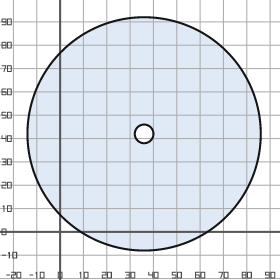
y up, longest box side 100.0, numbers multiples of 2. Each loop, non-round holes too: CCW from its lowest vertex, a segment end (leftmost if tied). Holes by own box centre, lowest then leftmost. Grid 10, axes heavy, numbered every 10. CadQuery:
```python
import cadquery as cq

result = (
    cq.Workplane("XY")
    .moveTo(36.0, 42.0)
    .circle(50.0)
    .moveTo(36.0, 42.0)
    .circle(4.0)
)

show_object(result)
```